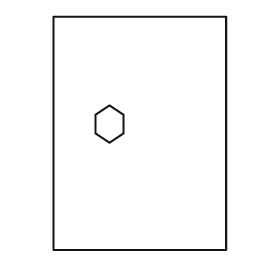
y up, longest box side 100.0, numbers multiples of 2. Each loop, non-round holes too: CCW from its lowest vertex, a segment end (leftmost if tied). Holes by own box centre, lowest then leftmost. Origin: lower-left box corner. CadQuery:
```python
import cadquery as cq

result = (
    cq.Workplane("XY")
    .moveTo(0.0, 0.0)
    .lineTo(74.0, 0.0)
    .lineTo(74.0, 100.0)
    .lineTo(0.0, 100.0)
    .close()
    .moveTo(24.0, 46.0)
    .lineTo(30.0, 50.0)
    .lineTo(30.0, 58.0)
    .lineTo(24.0, 62.0)
    .lineTo(18.0, 58.0)
    .lineTo(18.0, 50.0)
    .close()
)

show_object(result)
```